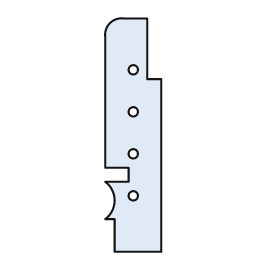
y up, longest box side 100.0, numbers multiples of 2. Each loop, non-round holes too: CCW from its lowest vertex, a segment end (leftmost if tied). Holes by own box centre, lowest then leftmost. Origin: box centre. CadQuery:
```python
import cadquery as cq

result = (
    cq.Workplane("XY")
    .moveTo(-8.0, -50.0)
    .lineTo(12.0, -50.0)
    .lineTo(12.0, 24.0)
    .lineTo(6.0, 24.0)
    .lineTo(6.0, 50.0)
    .lineTo(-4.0, 50.0)
    .threePointArc((-10.0, 48.0), (-12.0, 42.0))
    .lineTo(-12.0, -14.0)
    .lineTo(-2.0, -14.0)
    .lineTo(-2.0, -20.0)
    .lineTo(-12.0, -20.0)
    .threePointArc((-8.0, -28.0), (-12.0, -36.0))
    .lineTo(-8.0, -36.0)
    .close()
    .moveTo(0.0, -26.0)
    .circle(2.0)
    .moveTo(0.0, -8.0)
    .circle(2.0)
    .moveTo(0.0, 10.0)
    .circle(2.0)
    .moveTo(0.0, 28.0)
    .circle(2.0)
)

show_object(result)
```